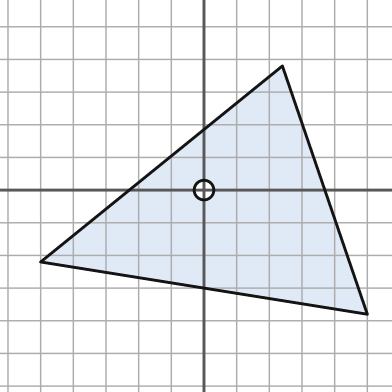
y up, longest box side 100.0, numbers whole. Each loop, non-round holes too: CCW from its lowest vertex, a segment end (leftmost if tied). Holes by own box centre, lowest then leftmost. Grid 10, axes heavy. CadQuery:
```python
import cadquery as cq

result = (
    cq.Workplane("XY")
    .moveTo(50.0, -38.0)
    .lineTo(24.0, 38.0)
    .lineTo(-50.0, -22.0)
    .close()
    .moveTo(0.0, 0.0)
    .circle(3.0)
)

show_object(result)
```